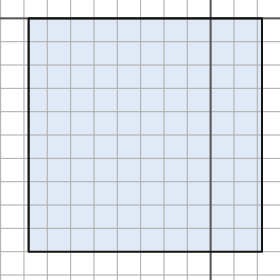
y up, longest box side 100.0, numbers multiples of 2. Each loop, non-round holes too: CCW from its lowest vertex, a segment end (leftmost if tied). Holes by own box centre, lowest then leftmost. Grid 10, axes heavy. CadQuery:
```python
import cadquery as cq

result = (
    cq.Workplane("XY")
    .moveTo(-78.0, -100.0)
    .lineTo(22.0, -100.0)
    .lineTo(22.0, 0.0)
    .lineTo(-78.0, 0.0)
    .close()
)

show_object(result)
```